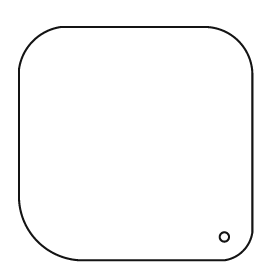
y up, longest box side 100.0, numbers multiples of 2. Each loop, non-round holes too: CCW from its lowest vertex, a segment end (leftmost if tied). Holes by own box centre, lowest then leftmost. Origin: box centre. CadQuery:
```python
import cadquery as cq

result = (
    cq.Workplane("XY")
    .moveTo(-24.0, -50.0)
    .lineTo(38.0, -50.0)
    .threePointArc((46.0, -46.0), (50.0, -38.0))
    .lineTo(50.0, 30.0)
    .threePointArc((44.0, 44.0), (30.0, 50.0))
    .lineTo(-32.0, 50.0)
    .threePointArc((-44.0, 44.0), (-50.0, 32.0))
    .lineTo(-50.0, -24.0)
    .threePointArc((-42.0, -42.0), (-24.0, -50.0))
    .close()
    .moveTo(38.0, -40.0)
    .circle(2.0)
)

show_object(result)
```